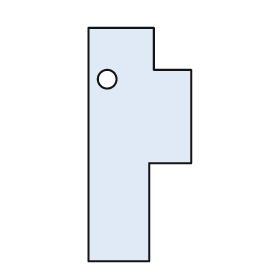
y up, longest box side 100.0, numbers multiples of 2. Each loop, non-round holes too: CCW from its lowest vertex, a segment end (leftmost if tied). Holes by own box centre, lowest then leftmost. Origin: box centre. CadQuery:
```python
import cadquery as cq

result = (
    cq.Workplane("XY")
    .moveTo(-22.0, -50.0)
    .lineTo(4.0, -50.0)
    .lineTo(4.0, -8.0)
    .lineTo(22.0, -8.0)
    .lineTo(22.0, 32.0)
    .lineTo(6.0, 32.0)
    .lineTo(6.0, 50.0)
    .lineTo(-22.0, 50.0)
    .close()
    .moveTo(-14.0, 28.0)
    .circle(4.0)
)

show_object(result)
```